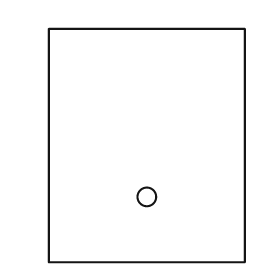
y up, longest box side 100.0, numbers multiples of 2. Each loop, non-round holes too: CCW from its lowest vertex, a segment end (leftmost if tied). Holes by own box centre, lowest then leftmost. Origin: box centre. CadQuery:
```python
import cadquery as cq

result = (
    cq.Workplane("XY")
    .moveTo(-42.0, -50.0)
    .lineTo(42.0, -50.0)
    .lineTo(42.0, 50.0)
    .lineTo(-42.0, 50.0)
    .close()
    .moveTo(0.0, -22.0)
    .circle(4.0)
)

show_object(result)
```